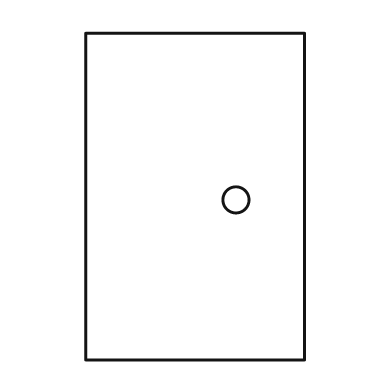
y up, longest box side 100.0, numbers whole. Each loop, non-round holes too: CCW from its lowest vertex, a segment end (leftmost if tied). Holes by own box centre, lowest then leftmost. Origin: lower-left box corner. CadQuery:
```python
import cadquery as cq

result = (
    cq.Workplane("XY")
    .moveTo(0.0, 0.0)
    .lineTo(67.0, 0.0)
    .lineTo(67.0, 100.0)
    .lineTo(0.0, 100.0)
    .close()
    .moveTo(46.0, 49.0)
    .circle(4.0)
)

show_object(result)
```